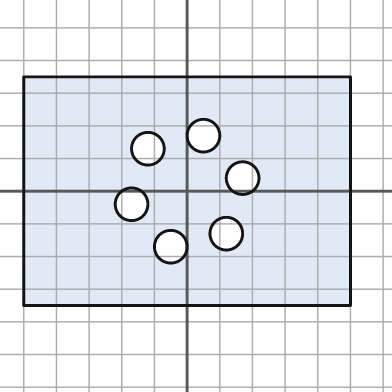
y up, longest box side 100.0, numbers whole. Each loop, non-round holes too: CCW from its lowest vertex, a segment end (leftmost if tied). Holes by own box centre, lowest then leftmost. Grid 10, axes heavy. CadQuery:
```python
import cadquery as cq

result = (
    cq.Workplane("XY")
    .moveTo(-50.0, -35.0)
    .lineTo(50.0, -35.0)
    .lineTo(50.0, 35.0)
    .lineTo(-50.0, 35.0)
    .close()
    .moveTo(-5.0, -17.0)
    .circle(5.0)
    .moveTo(12.0, -13.0)
    .circle(5.0)
    .moveTo(-17.0, -4.0)
    .circle(5.0)
    .moveTo(17.0, 4.0)
    .circle(5.0)
    .moveTo(-12.0, 13.0)
    .circle(5.0)
    .moveTo(5.0, 17.0)
    .circle(5.0)
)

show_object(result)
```